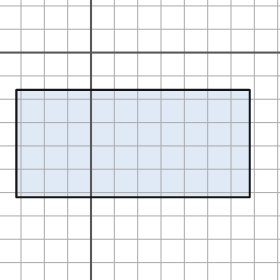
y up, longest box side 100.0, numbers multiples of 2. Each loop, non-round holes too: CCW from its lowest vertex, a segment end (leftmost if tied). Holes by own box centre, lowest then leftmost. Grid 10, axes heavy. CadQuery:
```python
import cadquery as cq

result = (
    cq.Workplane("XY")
    .moveTo(-32.0, -62.0)
    .lineTo(68.0, -62.0)
    .lineTo(68.0, -16.0)
    .lineTo(-32.0, -16.0)
    .close()
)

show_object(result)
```